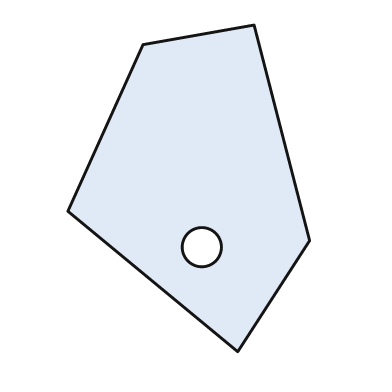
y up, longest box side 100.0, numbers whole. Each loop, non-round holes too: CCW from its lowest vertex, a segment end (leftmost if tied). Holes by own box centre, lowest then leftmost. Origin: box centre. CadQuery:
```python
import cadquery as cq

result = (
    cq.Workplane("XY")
    .moveTo(15.0, -50.0)
    .lineTo(37.0, -16.0)
    .lineTo(20.0, 50.0)
    .lineTo(-14.0, 44.0)
    .lineTo(-37.0, -7.0)
    .close()
    .moveTo(4.0, -18.0)
    .circle(6.0)
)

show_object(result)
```